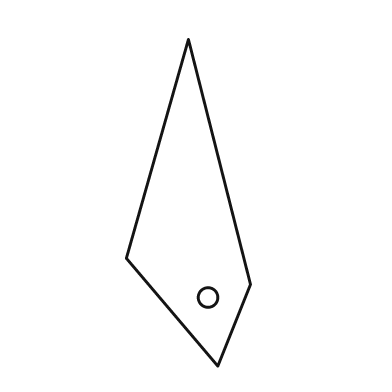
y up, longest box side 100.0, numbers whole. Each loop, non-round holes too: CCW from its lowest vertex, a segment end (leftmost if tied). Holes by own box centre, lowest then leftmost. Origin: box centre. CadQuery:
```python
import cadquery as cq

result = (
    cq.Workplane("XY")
    .moveTo(9.0, -50.0)
    .lineTo(19.0, -25.0)
    .lineTo(0.0, 50.0)
    .lineTo(-19.0, -17.0)
    .close()
    .moveTo(6.0, -29.0)
    .circle(3.0)
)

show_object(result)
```